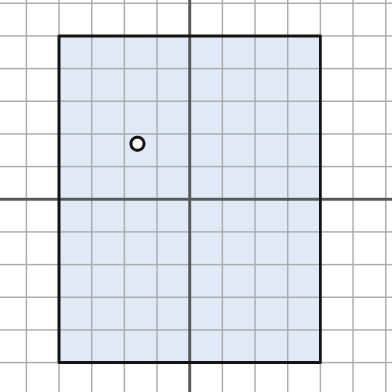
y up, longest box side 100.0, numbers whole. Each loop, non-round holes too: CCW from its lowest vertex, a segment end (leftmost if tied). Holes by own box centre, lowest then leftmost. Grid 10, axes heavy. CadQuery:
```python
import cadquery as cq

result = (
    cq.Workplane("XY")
    .moveTo(-40.0, -50.0)
    .lineTo(40.0, -50.0)
    .lineTo(40.0, 50.0)
    .lineTo(-40.0, 50.0)
    .close()
    .moveTo(-16.0, 17.0)
    .circle(2.0)
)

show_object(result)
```